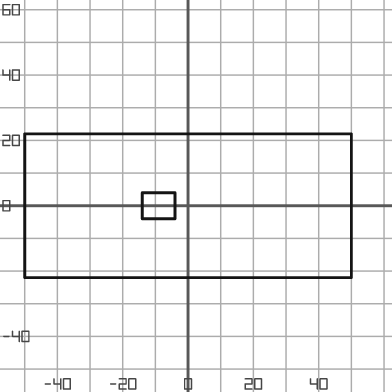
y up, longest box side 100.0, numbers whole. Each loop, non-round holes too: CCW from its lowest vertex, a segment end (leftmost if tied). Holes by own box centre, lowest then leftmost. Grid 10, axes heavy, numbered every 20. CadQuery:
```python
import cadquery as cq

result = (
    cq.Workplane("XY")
    .moveTo(-50.0, -22.0)
    .lineTo(50.0, -22.0)
    .lineTo(50.0, 22.0)
    .lineTo(-50.0, 22.0)
    .close()
    .moveTo(-14.0, -4.0)
    .lineTo(-4.0, -4.0)
    .lineTo(-4.0, 4.0)
    .lineTo(-14.0, 4.0)
    .close()
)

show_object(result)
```